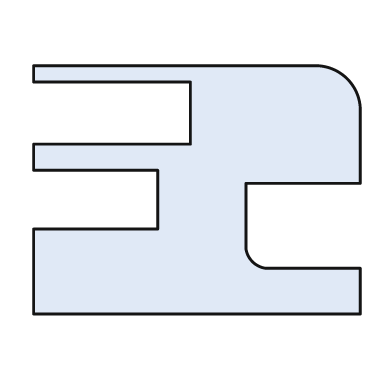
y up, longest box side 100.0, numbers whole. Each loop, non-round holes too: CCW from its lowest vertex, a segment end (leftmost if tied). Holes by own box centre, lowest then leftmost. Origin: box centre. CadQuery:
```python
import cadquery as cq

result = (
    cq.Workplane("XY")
    .moveTo(-50.0, -38.0)
    .lineTo(50.0, -38.0)
    .lineTo(50.0, -24.0)
    .lineTo(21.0, -24.0)
    .threePointArc((17.0, -22.0), (15.0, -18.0))
    .lineTo(15.0, 2.0)
    .lineTo(50.0, 2.0)
    .lineTo(50.0, 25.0)
    .threePointArc((46.0, 34.0), (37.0, 38.0))
    .lineTo(-50.0, 38.0)
    .lineTo(-50.0, 33.0)
    .lineTo(-2.0, 33.0)
    .lineTo(-2.0, 14.0)
    .lineTo(-50.0, 14.0)
    .lineTo(-50.0, 6.0)
    .lineTo(-12.0, 6.0)
    .lineTo(-12.0, -12.0)
    .lineTo(-50.0, -12.0)
    .close()
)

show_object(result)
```